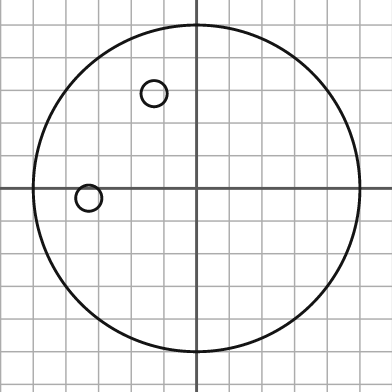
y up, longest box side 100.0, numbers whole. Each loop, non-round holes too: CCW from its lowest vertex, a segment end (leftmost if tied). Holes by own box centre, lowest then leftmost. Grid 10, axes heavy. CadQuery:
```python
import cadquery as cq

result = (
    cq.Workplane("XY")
    .moveTo(0.0, 0.0)
    .circle(50.0)
    .moveTo(-33.0, -3.0)
    .circle(4.0)
    .moveTo(-13.0, 29.0)
    .circle(4.0)
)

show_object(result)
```